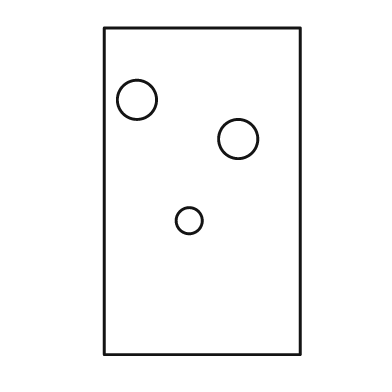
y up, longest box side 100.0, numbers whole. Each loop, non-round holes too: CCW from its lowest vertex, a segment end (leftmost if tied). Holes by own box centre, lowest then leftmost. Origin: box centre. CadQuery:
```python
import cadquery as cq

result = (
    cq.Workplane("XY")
    .moveTo(-30.0, -50.0)
    .lineTo(30.0, -50.0)
    .lineTo(30.0, 50.0)
    .lineTo(-30.0, 50.0)
    .close()
    .moveTo(-4.0, -9.0)
    .circle(4.0)
    .moveTo(11.0, 16.0)
    .circle(6.0)
    .moveTo(-20.0, 28.0)
    .circle(6.0)
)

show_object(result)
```